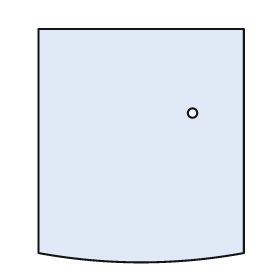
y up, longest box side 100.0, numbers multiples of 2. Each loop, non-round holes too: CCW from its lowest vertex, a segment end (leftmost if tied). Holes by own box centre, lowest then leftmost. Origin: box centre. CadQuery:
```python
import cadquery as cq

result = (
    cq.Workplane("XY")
    .moveTo(-44.0, -46.0)
    .threePointArc((0.0, -50.0), (44.0, -46.0))
    .lineTo(44.0, 50.0)
    .lineTo(-44.0, 50.0)
    .close()
    .moveTo(22.0, 14.0)
    .circle(2.0)
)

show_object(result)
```